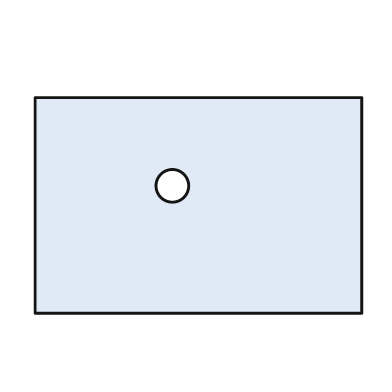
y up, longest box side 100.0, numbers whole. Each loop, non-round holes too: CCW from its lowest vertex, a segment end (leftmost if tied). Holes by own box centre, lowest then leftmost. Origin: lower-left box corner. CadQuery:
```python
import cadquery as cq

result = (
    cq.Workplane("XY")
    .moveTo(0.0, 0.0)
    .lineTo(100.0, 0.0)
    .lineTo(100.0, 66.0)
    .lineTo(0.0, 66.0)
    .close()
    .moveTo(42.0, 39.0)
    .circle(5.0)
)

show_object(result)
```